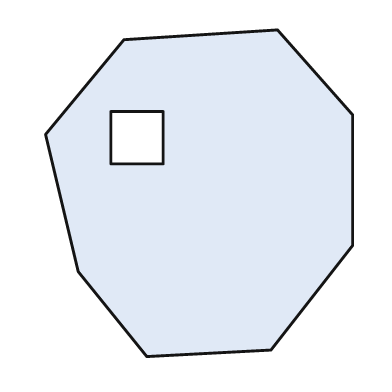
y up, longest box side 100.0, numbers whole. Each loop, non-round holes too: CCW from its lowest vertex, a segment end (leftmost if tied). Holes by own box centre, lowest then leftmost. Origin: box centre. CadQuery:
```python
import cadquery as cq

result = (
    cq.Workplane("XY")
    .moveTo(-16.0, -50.0)
    .lineTo(22.0, -48.0)
    .lineTo(47.0, -16.0)
    .lineTo(47.0, 24.0)
    .lineTo(24.0, 50.0)
    .lineTo(-23.0, 47.0)
    .lineTo(-47.0, 18.0)
    .lineTo(-37.0, -24.0)
    .close()
    .moveTo(-27.0, 9.0)
    .lineTo(-11.0, 9.0)
    .lineTo(-11.0, 25.0)
    .lineTo(-27.0, 25.0)
    .close()
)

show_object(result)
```